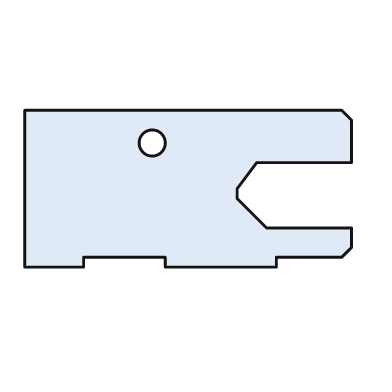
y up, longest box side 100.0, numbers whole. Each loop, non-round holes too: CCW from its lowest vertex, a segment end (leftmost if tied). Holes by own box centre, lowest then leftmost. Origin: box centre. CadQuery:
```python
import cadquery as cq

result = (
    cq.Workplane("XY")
    .moveTo(-50.0, -24.0)
    .lineTo(-32.0, -24.0)
    .lineTo(-32.0, -21.0)
    .lineTo(-7.0, -21.0)
    .lineTo(-7.0, -24.0)
    .lineTo(27.0, -24.0)
    .lineTo(27.0, -21.0)
    .lineTo(47.0, -21.0)
    .lineTo(50.0, -18.0)
    .lineTo(50.0, -12.0)
    .lineTo(24.0, -12.0)
    .lineTo(15.0, -3.0)
    .lineTo(15.0, 0.0)
    .lineTo(21.0, 8.0)
    .lineTo(50.0, 8.0)
    .lineTo(50.0, 21.0)
    .lineTo(47.0, 24.0)
    .lineTo(-50.0, 24.0)
    .close()
    .moveTo(-11.0, 14.0)
    .circle(4.0)
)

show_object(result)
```